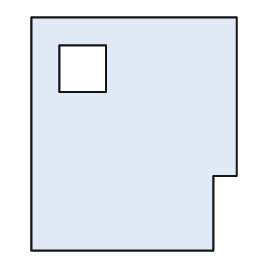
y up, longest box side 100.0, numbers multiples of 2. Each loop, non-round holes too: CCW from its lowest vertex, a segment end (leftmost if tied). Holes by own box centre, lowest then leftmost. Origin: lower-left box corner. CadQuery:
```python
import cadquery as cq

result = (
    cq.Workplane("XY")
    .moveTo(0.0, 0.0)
    .lineTo(78.0, 0.0)
    .lineTo(78.0, 32.0)
    .lineTo(88.0, 32.0)
    .lineTo(88.0, 100.0)
    .lineTo(0.0, 100.0)
    .close()
    .moveTo(12.0, 68.0)
    .lineTo(32.0, 68.0)
    .lineTo(32.0, 88.0)
    .lineTo(12.0, 88.0)
    .close()
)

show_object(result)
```